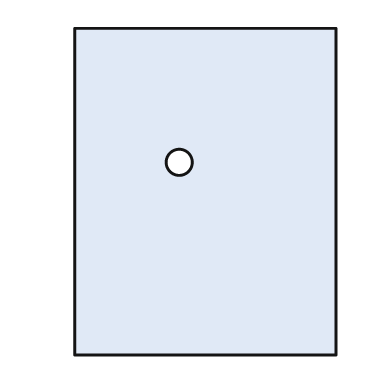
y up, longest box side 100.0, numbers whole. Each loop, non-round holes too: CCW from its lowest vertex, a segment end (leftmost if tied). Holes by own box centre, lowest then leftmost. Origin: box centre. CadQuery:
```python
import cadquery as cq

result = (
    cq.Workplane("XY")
    .moveTo(-40.0, -50.0)
    .lineTo(40.0, -50.0)
    .lineTo(40.0, 50.0)
    .lineTo(-40.0, 50.0)
    .close()
    .moveTo(-8.0, 9.0)
    .circle(4.0)
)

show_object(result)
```